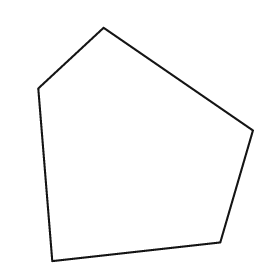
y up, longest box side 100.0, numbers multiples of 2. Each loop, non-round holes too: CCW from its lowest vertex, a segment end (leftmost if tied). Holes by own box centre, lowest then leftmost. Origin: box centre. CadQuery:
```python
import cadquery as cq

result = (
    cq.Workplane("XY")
    .moveTo(-40.0, -50.0)
    .lineTo(32.0, -42.0)
    .lineTo(46.0, 6.0)
    .lineTo(-18.0, 50.0)
    .lineTo(-46.0, 24.0)
    .close()
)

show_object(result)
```